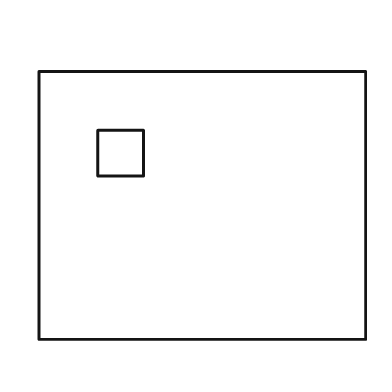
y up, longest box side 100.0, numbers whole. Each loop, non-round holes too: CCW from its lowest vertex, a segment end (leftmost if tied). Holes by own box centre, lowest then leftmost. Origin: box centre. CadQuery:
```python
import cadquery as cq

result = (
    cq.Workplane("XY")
    .moveTo(-50.0, -41.0)
    .lineTo(50.0, -41.0)
    .lineTo(50.0, 41.0)
    .lineTo(-50.0, 41.0)
    .close()
    .moveTo(-32.0, 9.0)
    .lineTo(-18.0, 9.0)
    .lineTo(-18.0, 23.0)
    .lineTo(-32.0, 23.0)
    .close()
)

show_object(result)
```